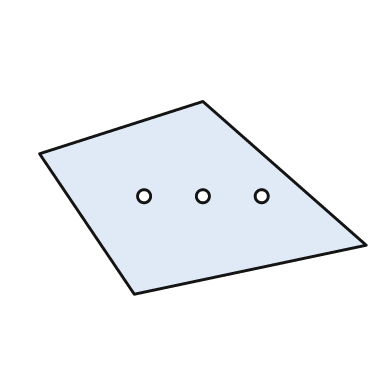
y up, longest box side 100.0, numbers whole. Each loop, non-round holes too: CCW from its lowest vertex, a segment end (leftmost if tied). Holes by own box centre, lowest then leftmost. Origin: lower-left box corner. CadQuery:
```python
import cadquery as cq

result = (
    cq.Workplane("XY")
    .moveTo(29.0, 0.0)
    .lineTo(100.0, 15.0)
    .lineTo(50.0, 59.0)
    .lineTo(0.0, 43.0)
    .close()
    .moveTo(32.0, 30.0)
    .circle(2.0)
    .moveTo(50.0, 30.0)
    .circle(2.0)
    .moveTo(68.0, 30.0)
    .circle(2.0)
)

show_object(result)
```